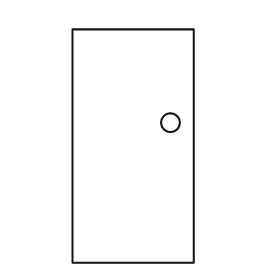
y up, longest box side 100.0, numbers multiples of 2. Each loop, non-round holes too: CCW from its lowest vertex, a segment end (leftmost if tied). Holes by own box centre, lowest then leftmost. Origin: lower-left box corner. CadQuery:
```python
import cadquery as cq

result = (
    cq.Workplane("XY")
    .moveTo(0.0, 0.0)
    .lineTo(52.0, 0.0)
    .lineTo(52.0, 100.0)
    .lineTo(0.0, 100.0)
    .close()
    .moveTo(42.0, 60.0)
    .circle(4.0)
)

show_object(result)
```